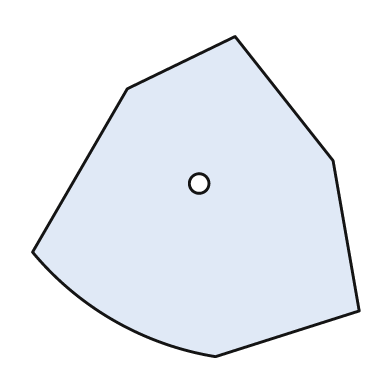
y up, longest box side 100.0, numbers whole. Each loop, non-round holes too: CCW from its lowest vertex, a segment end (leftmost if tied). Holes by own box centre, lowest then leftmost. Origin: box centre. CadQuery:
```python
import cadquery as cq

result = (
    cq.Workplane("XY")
    .moveTo(6.0, -49.0)
    .lineTo(50.0, -35.0)
    .lineTo(42.0, 11.0)
    .lineTo(12.0, 49.0)
    .lineTo(-21.0, 33.0)
    .lineTo(-50.0, -17.0)
    .threePointArc((-25.0, -38.0), (6.0, -49.0))
    .close()
    .moveTo(1.0, 4.0)
    .circle(3.0)
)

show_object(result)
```